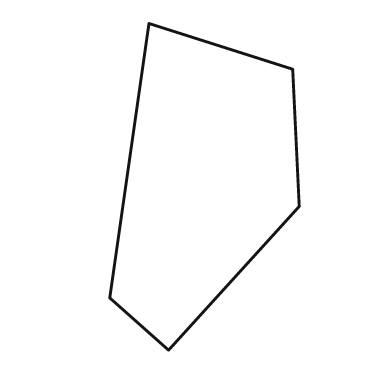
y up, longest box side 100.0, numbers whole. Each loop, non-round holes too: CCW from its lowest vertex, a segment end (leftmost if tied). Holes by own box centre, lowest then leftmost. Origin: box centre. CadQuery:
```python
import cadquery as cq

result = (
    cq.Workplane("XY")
    .moveTo(-11.0, -50.0)
    .lineTo(29.0, -6.0)
    .lineTo(27.0, 36.0)
    .lineTo(-17.0, 50.0)
    .lineTo(-29.0, -34.0)
    .close()
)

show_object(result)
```